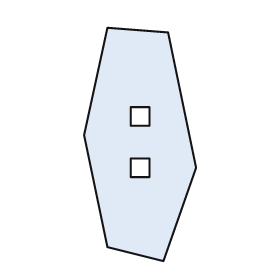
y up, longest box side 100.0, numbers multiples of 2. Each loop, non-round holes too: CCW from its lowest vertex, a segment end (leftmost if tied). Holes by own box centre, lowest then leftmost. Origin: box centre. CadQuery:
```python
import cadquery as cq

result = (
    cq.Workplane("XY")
    .moveTo(10.0, -50.0)
    .lineTo(24.0, -10.0)
    .lineTo(12.0, 48.0)
    .lineTo(-14.0, 50.0)
    .lineTo(-24.0, 4.0)
    .lineTo(-14.0, -44.0)
    .close()
    .moveTo(-4.0, -14.0)
    .lineTo(4.0, -14.0)
    .lineTo(4.0, -6.0)
    .lineTo(-4.0, -6.0)
    .close()
    .moveTo(-4.0, 8.0)
    .lineTo(4.0, 8.0)
    .lineTo(4.0, 16.0)
    .lineTo(-4.0, 16.0)
    .close()
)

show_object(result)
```